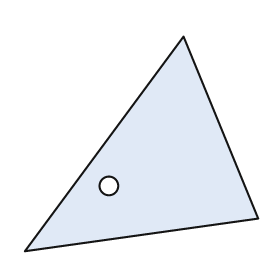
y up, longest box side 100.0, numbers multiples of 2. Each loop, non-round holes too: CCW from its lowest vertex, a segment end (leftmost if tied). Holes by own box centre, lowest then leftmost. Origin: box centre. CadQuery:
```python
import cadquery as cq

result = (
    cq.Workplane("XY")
    .moveTo(-50.0, -46.0)
    .lineTo(50.0, -32.0)
    .lineTo(18.0, 46.0)
    .close()
    .moveTo(-14.0, -18.0)
    .circle(4.0)
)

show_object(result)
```